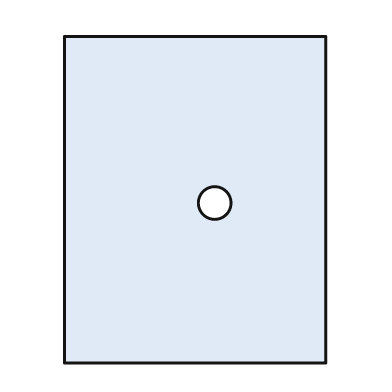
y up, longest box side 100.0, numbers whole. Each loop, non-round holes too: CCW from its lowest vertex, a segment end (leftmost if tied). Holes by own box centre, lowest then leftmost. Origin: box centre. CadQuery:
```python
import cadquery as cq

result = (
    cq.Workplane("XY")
    .moveTo(-40.0, -50.0)
    .lineTo(40.0, -50.0)
    .lineTo(40.0, 50.0)
    .lineTo(-40.0, 50.0)
    .close()
    .moveTo(6.0, -1.0)
    .circle(5.0)
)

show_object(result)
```